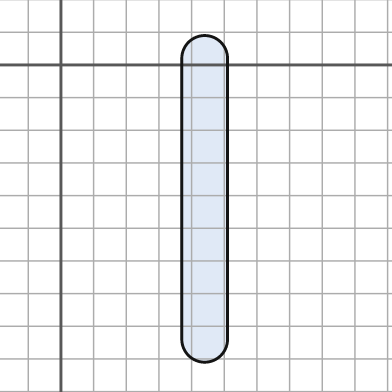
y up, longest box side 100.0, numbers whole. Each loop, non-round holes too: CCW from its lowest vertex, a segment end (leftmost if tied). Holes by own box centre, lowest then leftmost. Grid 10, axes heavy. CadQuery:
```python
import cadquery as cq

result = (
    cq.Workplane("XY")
    .moveTo(37.0, -84.0)
    .threePointArc((44.0, -91.0), (51.0, -84.0))
    .lineTo(51.0, 2.0)
    .threePointArc((44.0, 9.0), (37.0, 2.0))
    .close()
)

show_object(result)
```